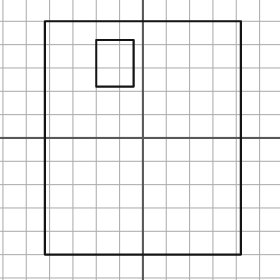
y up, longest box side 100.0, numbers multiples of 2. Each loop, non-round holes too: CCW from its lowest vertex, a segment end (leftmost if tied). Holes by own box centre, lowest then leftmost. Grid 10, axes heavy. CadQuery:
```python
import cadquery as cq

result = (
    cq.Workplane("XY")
    .moveTo(-42.0, -50.0)
    .lineTo(42.0, -50.0)
    .lineTo(42.0, 50.0)
    .lineTo(-42.0, 50.0)
    .close()
    .moveTo(-20.0, 22.0)
    .lineTo(-4.0, 22.0)
    .lineTo(-4.0, 42.0)
    .lineTo(-20.0, 42.0)
    .close()
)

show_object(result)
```